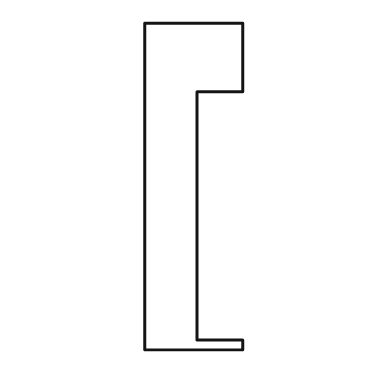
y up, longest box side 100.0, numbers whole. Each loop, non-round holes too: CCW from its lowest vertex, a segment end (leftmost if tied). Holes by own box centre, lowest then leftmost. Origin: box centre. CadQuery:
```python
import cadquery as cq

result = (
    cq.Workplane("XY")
    .moveTo(-15.0, -50.0)
    .lineTo(15.0, -50.0)
    .lineTo(15.0, -47.0)
    .lineTo(1.0, -47.0)
    .lineTo(1.0, 29.0)
    .lineTo(15.0, 29.0)
    .lineTo(15.0, 50.0)
    .lineTo(-15.0, 50.0)
    .close()
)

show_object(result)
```